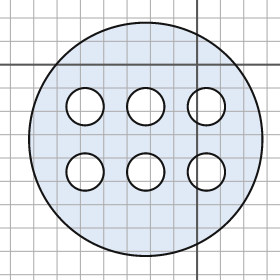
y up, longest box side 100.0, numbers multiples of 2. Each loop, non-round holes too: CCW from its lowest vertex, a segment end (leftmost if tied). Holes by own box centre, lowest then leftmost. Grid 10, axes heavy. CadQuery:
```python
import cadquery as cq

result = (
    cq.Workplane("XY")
    .moveTo(-22.0, -32.0)
    .circle(50.0)
    .moveTo(-48.0, -46.0)
    .circle(8.0)
    .moveTo(-22.0, -46.0)
    .circle(8.0)
    .moveTo(4.0, -46.0)
    .circle(8.0)
    .moveTo(-48.0, -18.0)
    .circle(8.0)
    .moveTo(-22.0, -18.0)
    .circle(8.0)
    .moveTo(4.0, -18.0)
    .circle(8.0)
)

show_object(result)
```